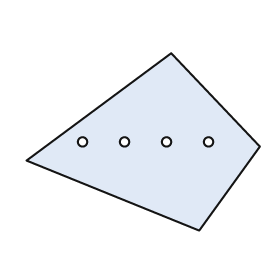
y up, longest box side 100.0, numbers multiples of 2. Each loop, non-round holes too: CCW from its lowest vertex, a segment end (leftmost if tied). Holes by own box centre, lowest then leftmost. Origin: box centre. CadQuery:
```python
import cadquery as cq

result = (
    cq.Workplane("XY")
    .moveTo(24.0, -38.0)
    .lineTo(50.0, -2.0)
    .lineTo(12.0, 38.0)
    .lineTo(-50.0, -8.0)
    .close()
    .moveTo(-26.0, 0.0)
    .circle(2.0)
    .moveTo(-8.0, 0.0)
    .circle(2.0)
    .moveTo(10.0, 0.0)
    .circle(2.0)
    .moveTo(28.0, 0.0)
    .circle(2.0)
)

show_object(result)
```